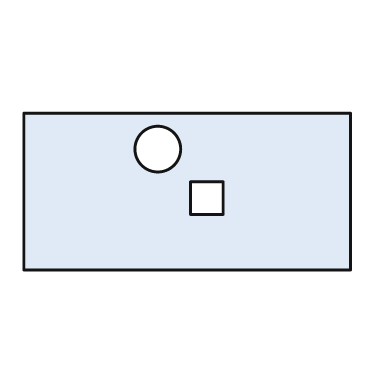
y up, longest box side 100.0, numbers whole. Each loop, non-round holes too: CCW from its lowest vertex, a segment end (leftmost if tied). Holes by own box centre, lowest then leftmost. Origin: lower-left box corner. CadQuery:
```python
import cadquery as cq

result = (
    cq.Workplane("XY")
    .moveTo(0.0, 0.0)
    .lineTo(100.0, 0.0)
    .lineTo(100.0, 48.0)
    .lineTo(0.0, 48.0)
    .close()
    .moveTo(51.0, 17.0)
    .lineTo(61.0, 17.0)
    .lineTo(61.0, 27.0)
    .lineTo(51.0, 27.0)
    .close()
    .moveTo(41.0, 37.0)
    .circle(7.0)
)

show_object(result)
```